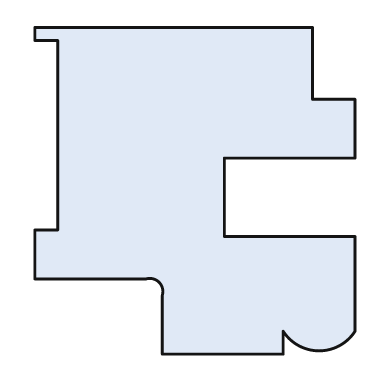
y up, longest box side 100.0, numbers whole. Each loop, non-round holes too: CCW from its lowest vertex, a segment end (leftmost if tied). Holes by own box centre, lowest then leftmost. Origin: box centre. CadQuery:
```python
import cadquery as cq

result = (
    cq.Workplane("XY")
    .moveTo(-10.0, -50.0)
    .lineTo(27.0, -50.0)
    .lineTo(27.0, -43.0)
    .threePointArc((38.0, -49.0), (49.0, -43.0))
    .lineTo(49.0, -14.0)
    .lineTo(9.0, -14.0)
    .lineTo(9.0, 10.0)
    .lineTo(49.0, 10.0)
    .lineTo(49.0, 28.0)
    .lineTo(36.0, 28.0)
    .lineTo(36.0, 50.0)
    .lineTo(-49.0, 50.0)
    .lineTo(-49.0, 46.0)
    .lineTo(-42.0, 46.0)
    .lineTo(-42.0, -12.0)
    .lineTo(-49.0, -12.0)
    .lineTo(-49.0, -27.0)
    .lineTo(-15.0, -27.0)
    .threePointArc((-11.0, -28.0), (-10.0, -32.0))
    .close()
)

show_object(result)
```